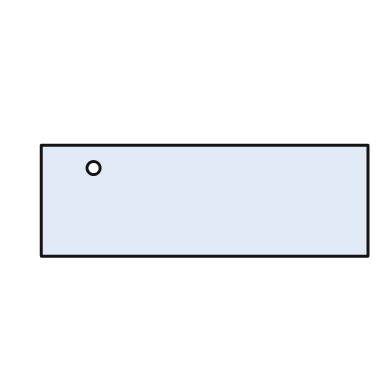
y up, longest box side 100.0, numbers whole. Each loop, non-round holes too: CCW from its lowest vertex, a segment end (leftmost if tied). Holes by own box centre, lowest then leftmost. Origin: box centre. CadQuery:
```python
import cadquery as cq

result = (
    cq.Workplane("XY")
    .moveTo(-50.0, -17.0)
    .lineTo(50.0, -17.0)
    .lineTo(50.0, 17.0)
    .lineTo(-50.0, 17.0)
    .close()
    .moveTo(-34.0, 10.0)
    .circle(2.0)
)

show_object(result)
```